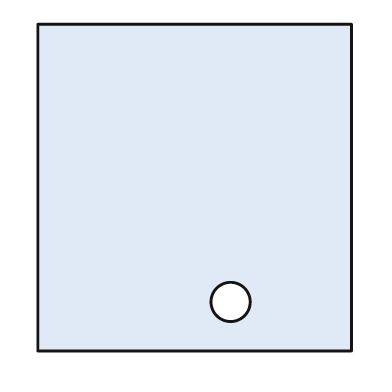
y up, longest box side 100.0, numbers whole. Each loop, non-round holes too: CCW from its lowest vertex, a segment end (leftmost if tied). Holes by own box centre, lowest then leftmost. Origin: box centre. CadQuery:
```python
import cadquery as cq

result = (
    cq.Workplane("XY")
    .moveTo(-48.0, -50.0)
    .lineTo(48.0, -50.0)
    .lineTo(48.0, 50.0)
    .lineTo(-48.0, 50.0)
    .close()
    .moveTo(11.0, -35.0)
    .circle(6.0)
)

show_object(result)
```